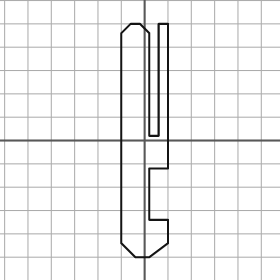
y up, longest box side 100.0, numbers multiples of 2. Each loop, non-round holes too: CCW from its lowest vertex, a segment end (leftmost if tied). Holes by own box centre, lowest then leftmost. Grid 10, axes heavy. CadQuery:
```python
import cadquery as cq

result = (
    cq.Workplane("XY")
    .moveTo(-4.0, -50.0)
    .lineTo(2.0, -50.0)
    .lineTo(10.0, -44.0)
    .lineTo(10.0, -34.0)
    .lineTo(2.0, -34.0)
    .lineTo(2.0, -12.0)
    .lineTo(10.0, -12.0)
    .lineTo(10.0, 50.0)
    .lineTo(6.0, 50.0)
    .lineTo(6.0, 2.0)
    .lineTo(2.0, 2.0)
    .lineTo(2.0, 46.0)
    .lineTo(-2.0, 50.0)
    .lineTo(-6.0, 50.0)
    .lineTo(-10.0, 46.0)
    .lineTo(-10.0, -44.0)
    .close()
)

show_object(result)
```